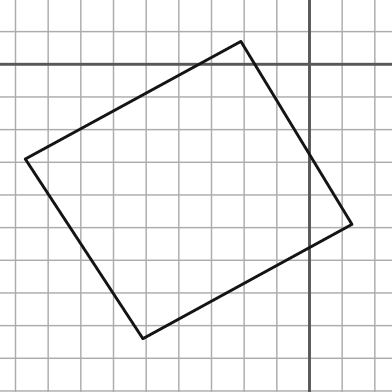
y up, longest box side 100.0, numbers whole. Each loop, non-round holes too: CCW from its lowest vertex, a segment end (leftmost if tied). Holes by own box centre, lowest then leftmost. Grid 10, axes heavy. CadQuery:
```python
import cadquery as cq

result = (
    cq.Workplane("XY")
    .moveTo(-51.0, -84.0)
    .lineTo(13.0, -49.0)
    .lineTo(-21.0, 7.0)
    .lineTo(-87.0, -29.0)
    .close()
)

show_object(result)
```